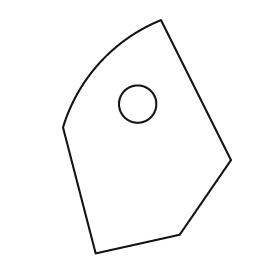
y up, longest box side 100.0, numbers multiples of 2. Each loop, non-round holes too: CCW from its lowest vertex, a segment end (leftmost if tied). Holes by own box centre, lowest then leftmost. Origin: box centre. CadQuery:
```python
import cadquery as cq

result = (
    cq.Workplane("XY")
    .moveTo(-22.0, -50.0)
    .lineTo(14.0, -42.0)
    .lineTo(36.0, -10.0)
    .lineTo(6.0, 50.0)
    .threePointArc((-20.0, 32.0), (-36.0, 4.0))
    .close()
    .moveTo(-4.0, 14.0)
    .circle(8.0)
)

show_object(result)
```